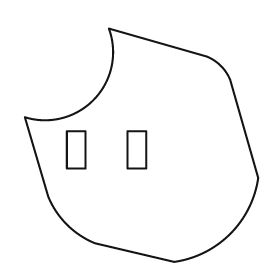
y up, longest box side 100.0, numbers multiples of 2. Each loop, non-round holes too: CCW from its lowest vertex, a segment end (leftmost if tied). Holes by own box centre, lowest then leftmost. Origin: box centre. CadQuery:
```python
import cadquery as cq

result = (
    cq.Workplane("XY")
    .moveTo(14.0, -50.0)
    .threePointArc((38.0, -38.0), (50.0, -14.0))
    .lineTo(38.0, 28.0)
    .threePointArc((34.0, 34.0), (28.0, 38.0))
    .lineTo(-14.0, 50.0)
    .threePointArc((-20.0, 20.0), (-50.0, 12.0))
    .lineTo(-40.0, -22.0)
    .threePointArc((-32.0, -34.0), (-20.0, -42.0))
    .close()
    .moveTo(-32.0, -10.0)
    .lineTo(-24.0, -10.0)
    .lineTo(-24.0, 6.0)
    .lineTo(-32.0, 6.0)
    .close()
    .moveTo(-6.0, -10.0)
    .lineTo(2.0, -10.0)
    .lineTo(2.0, 6.0)
    .lineTo(-6.0, 6.0)
    .close()
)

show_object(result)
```